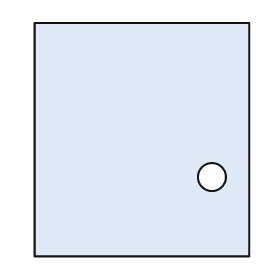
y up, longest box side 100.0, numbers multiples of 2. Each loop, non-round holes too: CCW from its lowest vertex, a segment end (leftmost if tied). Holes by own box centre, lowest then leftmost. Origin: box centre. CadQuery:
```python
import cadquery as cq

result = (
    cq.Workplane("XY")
    .moveTo(-46.0, -50.0)
    .lineTo(46.0, -50.0)
    .lineTo(46.0, 50.0)
    .lineTo(-46.0, 50.0)
    .close()
    .moveTo(30.0, -16.0)
    .circle(6.0)
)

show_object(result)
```